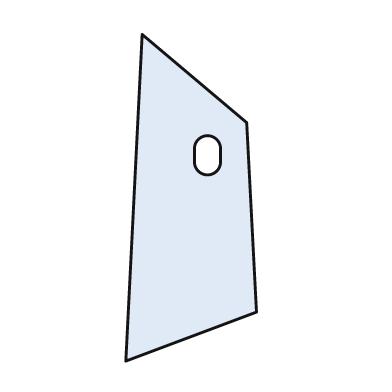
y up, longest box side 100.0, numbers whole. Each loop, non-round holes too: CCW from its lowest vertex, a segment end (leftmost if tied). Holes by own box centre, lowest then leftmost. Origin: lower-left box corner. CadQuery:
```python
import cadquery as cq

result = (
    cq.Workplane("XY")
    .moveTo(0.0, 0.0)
    .lineTo(40.0, 15.0)
    .lineTo(37.0, 73.0)
    .lineTo(5.0, 100.0)
    .close()
    .moveTo(21.0, 61.0)
    .threePointArc((25.0, 57.0), (29.0, 61.0))
    .lineTo(29.0, 65.0)
    .threePointArc((25.0, 69.0), (21.0, 65.0))
    .close()
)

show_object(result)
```